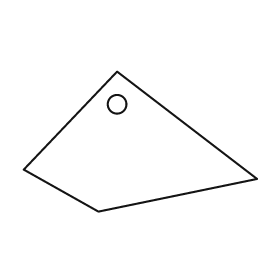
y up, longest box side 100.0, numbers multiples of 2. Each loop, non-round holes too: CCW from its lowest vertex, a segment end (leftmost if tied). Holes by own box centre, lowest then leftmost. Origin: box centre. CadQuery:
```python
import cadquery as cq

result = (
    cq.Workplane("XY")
    .moveTo(-18.0, -30.0)
    .lineTo(50.0, -16.0)
    .lineTo(-10.0, 30.0)
    .lineTo(-50.0, -12.0)
    .close()
    .moveTo(-10.0, 16.0)
    .circle(4.0)
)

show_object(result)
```